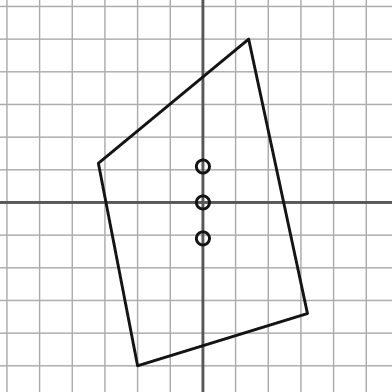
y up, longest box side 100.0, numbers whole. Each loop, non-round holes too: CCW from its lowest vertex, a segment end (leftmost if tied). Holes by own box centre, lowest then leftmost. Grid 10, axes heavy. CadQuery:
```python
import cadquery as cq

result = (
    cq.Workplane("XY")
    .moveTo(-20.0, -50.0)
    .lineTo(32.0, -34.0)
    .lineTo(14.0, 50.0)
    .lineTo(-32.0, 12.0)
    .close()
    .moveTo(0.0, -11.0)
    .circle(2.0)
    .moveTo(0.0, 0.0)
    .circle(2.0)
    .moveTo(0.0, 11.0)
    .circle(2.0)
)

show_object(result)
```